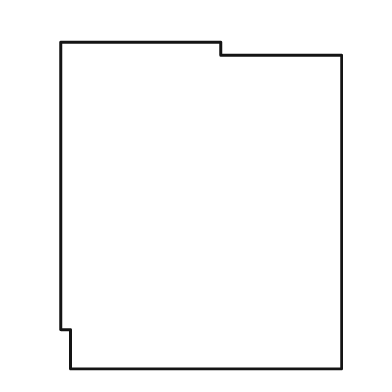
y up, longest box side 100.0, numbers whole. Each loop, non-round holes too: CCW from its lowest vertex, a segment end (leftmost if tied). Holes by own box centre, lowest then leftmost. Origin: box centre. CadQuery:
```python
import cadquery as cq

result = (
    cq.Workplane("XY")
    .moveTo(-40.0, -50.0)
    .lineTo(43.0, -50.0)
    .lineTo(43.0, 46.0)
    .lineTo(6.0, 46.0)
    .lineTo(6.0, 50.0)
    .lineTo(-43.0, 50.0)
    .lineTo(-43.0, -38.0)
    .lineTo(-40.0, -38.0)
    .close()
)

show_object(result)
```